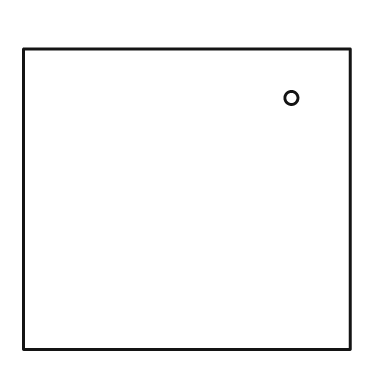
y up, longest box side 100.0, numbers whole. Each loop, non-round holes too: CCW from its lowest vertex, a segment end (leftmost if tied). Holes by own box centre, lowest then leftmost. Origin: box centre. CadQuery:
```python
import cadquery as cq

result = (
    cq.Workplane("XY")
    .moveTo(-50.0, -46.0)
    .lineTo(50.0, -46.0)
    .lineTo(50.0, 46.0)
    .lineTo(-50.0, 46.0)
    .close()
    .moveTo(32.0, 31.0)
    .circle(2.0)
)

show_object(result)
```